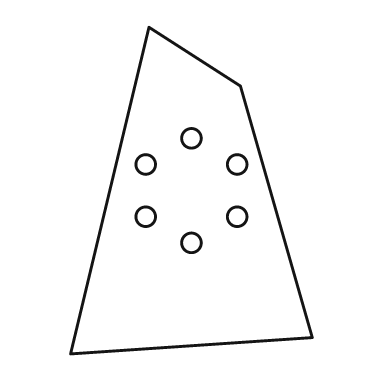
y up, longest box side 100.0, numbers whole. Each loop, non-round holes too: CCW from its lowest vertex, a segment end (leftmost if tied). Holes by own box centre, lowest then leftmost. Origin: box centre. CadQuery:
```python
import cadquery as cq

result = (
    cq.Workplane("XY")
    .moveTo(-37.0, -50.0)
    .lineTo(37.0, -45.0)
    .lineTo(15.0, 32.0)
    .lineTo(-13.0, 50.0)
    .close()
    .moveTo(0.0, -16.0)
    .circle(3.0)
    .moveTo(-14.0, -8.0)
    .circle(3.0)
    .moveTo(14.0, -8.0)
    .circle(3.0)
    .moveTo(-14.0, 8.0)
    .circle(3.0)
    .moveTo(14.0, 8.0)
    .circle(3.0)
    .moveTo(0.0, 16.0)
    .circle(3.0)
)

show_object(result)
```